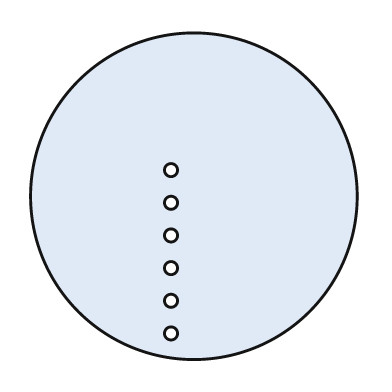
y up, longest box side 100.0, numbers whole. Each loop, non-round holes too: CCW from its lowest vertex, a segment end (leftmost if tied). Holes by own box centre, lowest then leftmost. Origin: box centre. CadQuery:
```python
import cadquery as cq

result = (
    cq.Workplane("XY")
    .moveTo(0.0, 0.0)
    .circle(50.0)
    .moveTo(-7.0, -42.0)
    .circle(2.0)
    .moveTo(-7.0, -32.0)
    .circle(2.0)
    .moveTo(-7.0, -22.0)
    .circle(2.0)
    .moveTo(-7.0, -12.0)
    .circle(2.0)
    .moveTo(-7.0, -2.0)
    .circle(2.0)
    .moveTo(-7.0, 8.0)
    .circle(2.0)
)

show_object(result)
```